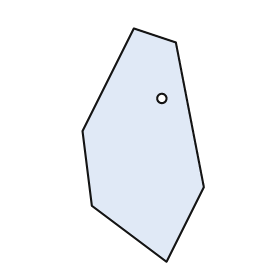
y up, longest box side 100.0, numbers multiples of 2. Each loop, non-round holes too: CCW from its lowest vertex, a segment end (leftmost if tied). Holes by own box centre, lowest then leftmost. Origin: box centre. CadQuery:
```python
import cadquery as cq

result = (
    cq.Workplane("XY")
    .moveTo(10.0, -50.0)
    .lineTo(26.0, -18.0)
    .lineTo(14.0, 44.0)
    .lineTo(-4.0, 50.0)
    .lineTo(-26.0, 6.0)
    .lineTo(-22.0, -26.0)
    .close()
    .moveTo(8.0, 20.0)
    .circle(2.0)
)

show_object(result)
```